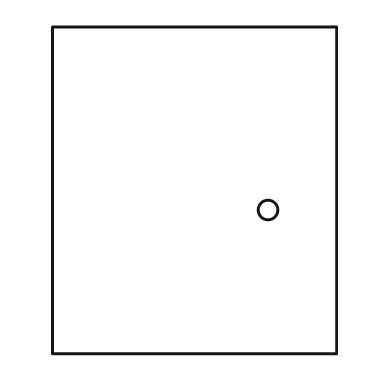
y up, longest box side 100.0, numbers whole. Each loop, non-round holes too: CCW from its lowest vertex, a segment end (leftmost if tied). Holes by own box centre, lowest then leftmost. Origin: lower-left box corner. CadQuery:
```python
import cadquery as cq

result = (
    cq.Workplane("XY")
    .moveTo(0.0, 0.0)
    .lineTo(87.0, 0.0)
    .lineTo(87.0, 100.0)
    .lineTo(0.0, 100.0)
    .close()
    .moveTo(66.0, 44.0)
    .circle(3.0)
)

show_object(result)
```